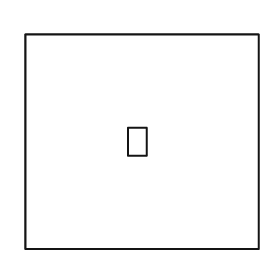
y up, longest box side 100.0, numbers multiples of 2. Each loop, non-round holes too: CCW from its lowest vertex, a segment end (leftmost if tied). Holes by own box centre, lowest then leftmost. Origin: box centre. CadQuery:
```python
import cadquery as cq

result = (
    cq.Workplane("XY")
    .moveTo(-50.0, -46.0)
    .lineTo(50.0, -46.0)
    .lineTo(50.0, 46.0)
    .lineTo(-50.0, 46.0)
    .close()
    .moveTo(-6.0, -6.0)
    .lineTo(2.0, -6.0)
    .lineTo(2.0, 6.0)
    .lineTo(-6.0, 6.0)
    .close()
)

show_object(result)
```